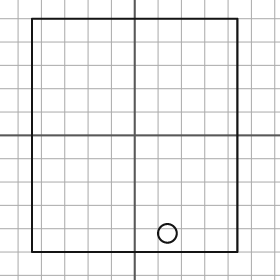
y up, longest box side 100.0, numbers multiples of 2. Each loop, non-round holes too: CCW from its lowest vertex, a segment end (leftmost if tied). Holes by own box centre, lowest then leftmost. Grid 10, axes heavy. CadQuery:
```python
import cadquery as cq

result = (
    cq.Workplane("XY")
    .moveTo(-44.0, -50.0)
    .lineTo(44.0, -50.0)
    .lineTo(44.0, 50.0)
    .lineTo(-44.0, 50.0)
    .close()
    .moveTo(14.0, -42.0)
    .circle(4.0)
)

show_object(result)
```